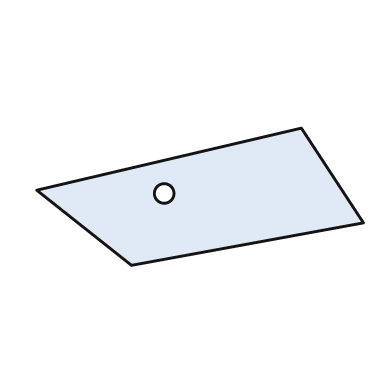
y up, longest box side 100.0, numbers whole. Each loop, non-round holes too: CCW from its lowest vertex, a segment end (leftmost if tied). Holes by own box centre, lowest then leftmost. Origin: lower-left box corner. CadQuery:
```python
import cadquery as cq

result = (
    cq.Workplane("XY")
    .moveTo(29.0, 0.0)
    .lineTo(100.0, 13.0)
    .lineTo(81.0, 42.0)
    .lineTo(0.0, 23.0)
    .close()
    .moveTo(39.0, 22.0)
    .circle(3.0)
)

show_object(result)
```